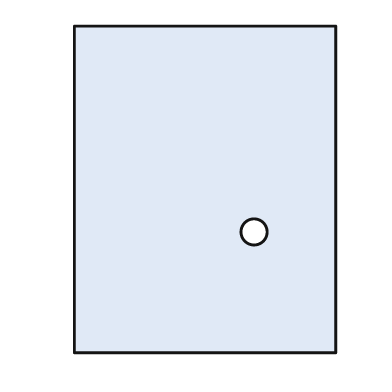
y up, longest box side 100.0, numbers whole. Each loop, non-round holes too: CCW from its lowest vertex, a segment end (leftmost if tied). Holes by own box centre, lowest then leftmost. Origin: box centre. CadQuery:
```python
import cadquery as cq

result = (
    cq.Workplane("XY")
    .moveTo(-40.0, -50.0)
    .lineTo(40.0, -50.0)
    .lineTo(40.0, 50.0)
    .lineTo(-40.0, 50.0)
    .close()
    .moveTo(15.0, -13.0)
    .circle(4.0)
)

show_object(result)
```